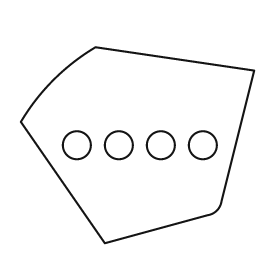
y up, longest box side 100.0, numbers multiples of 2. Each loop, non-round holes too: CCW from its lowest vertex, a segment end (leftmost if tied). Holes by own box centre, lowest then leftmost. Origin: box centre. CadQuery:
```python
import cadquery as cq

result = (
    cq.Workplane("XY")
    .moveTo(-14.0, -42.0)
    .lineTo(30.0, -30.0)
    .threePointArc((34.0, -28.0), (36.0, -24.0))
    .lineTo(50.0, 32.0)
    .lineTo(-18.0, 42.0)
    .threePointArc((-36.0, 28.0), (-50.0, 10.0))
    .close()
    .moveTo(-26.0, 0.0)
    .circle(6.0)
    .moveTo(-8.0, 0.0)
    .circle(6.0)
    .moveTo(10.0, 0.0)
    .circle(6.0)
    .moveTo(28.0, 0.0)
    .circle(6.0)
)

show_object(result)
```